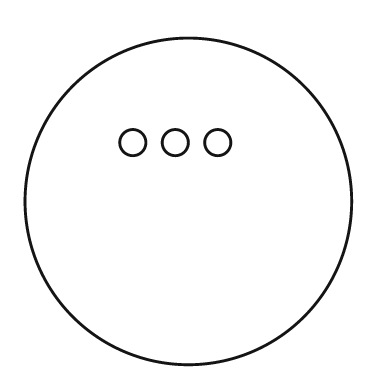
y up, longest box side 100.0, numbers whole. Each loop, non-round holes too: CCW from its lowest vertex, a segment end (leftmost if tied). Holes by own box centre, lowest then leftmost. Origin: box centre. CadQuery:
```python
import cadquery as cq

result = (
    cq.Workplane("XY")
    .moveTo(0.0, 0.0)
    .circle(50.0)
    .moveTo(-17.0, 18.0)
    .circle(4.0)
    .moveTo(-4.0, 18.0)
    .circle(4.0)
    .moveTo(9.0, 18.0)
    .circle(4.0)
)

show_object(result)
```